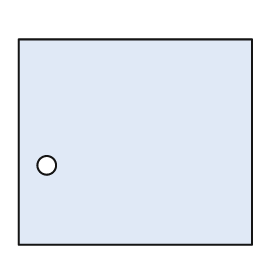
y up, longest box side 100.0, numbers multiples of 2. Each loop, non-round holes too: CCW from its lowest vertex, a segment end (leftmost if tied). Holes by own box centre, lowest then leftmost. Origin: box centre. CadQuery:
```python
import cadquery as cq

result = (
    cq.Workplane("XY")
    .moveTo(-50.0, -44.0)
    .lineTo(50.0, -44.0)
    .lineTo(50.0, 44.0)
    .lineTo(-50.0, 44.0)
    .close()
    .moveTo(-38.0, -10.0)
    .circle(4.0)
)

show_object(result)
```